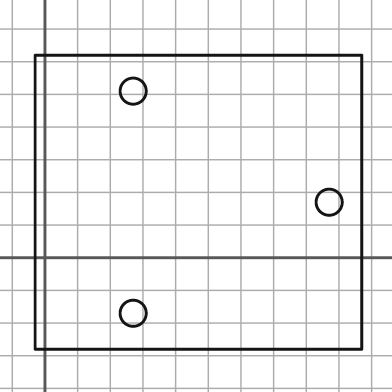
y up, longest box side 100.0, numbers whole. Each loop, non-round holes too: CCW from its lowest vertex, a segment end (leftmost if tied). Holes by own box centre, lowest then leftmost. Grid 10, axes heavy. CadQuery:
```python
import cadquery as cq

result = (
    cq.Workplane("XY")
    .moveTo(-3.0, -28.0)
    .lineTo(97.0, -28.0)
    .lineTo(97.0, 62.0)
    .lineTo(-3.0, 62.0)
    .close()
    .moveTo(27.0, -17.0)
    .circle(4.0)
    .moveTo(87.0, 17.0)
    .circle(4.0)
    .moveTo(27.0, 51.0)
    .circle(4.0)
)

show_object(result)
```